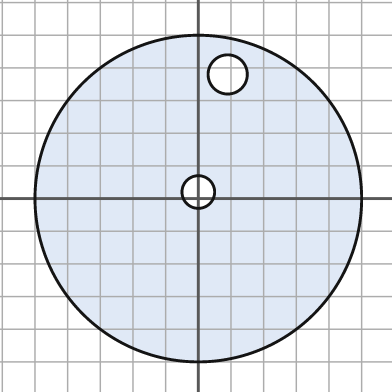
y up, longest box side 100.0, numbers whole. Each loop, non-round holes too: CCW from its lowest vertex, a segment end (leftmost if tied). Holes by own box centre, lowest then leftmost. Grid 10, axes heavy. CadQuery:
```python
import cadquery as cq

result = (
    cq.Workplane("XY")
    .moveTo(0.0, 0.0)
    .circle(50.0)
    .moveTo(0.0, 2.0)
    .circle(5.0)
    .moveTo(9.0, 38.0)
    .circle(6.0)
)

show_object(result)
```